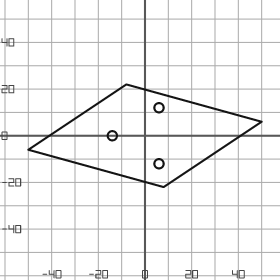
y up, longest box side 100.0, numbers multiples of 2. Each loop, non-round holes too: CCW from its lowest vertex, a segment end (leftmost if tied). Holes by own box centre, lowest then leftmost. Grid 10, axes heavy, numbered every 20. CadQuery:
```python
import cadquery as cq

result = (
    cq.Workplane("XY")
    .moveTo(8.0, -22.0)
    .lineTo(50.0, 6.0)
    .lineTo(-8.0, 22.0)
    .lineTo(-50.0, -6.0)
    .close()
    .moveTo(6.0, -12.0)
    .circle(2.0)
    .moveTo(-14.0, 0.0)
    .circle(2.0)
    .moveTo(6.0, 12.0)
    .circle(2.0)
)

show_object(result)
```